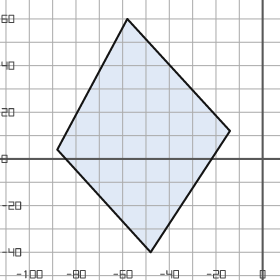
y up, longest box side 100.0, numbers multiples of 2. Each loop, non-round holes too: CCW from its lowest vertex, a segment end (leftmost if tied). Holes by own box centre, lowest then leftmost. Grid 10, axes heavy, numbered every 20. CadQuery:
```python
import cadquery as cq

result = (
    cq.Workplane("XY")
    .moveTo(-48.0, -40.0)
    .lineTo(-14.0, 12.0)
    .lineTo(-58.0, 60.0)
    .lineTo(-88.0, 4.0)
    .close()
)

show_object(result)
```